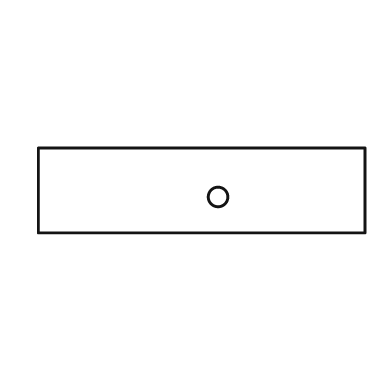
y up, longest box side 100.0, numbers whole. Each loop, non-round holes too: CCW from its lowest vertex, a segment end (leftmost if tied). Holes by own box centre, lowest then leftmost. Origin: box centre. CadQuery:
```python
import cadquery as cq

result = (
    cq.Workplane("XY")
    .moveTo(-50.0, -13.0)
    .lineTo(50.0, -13.0)
    .lineTo(50.0, 13.0)
    .lineTo(-50.0, 13.0)
    .close()
    .moveTo(5.0, -2.0)
    .circle(3.0)
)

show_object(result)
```